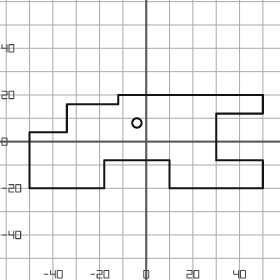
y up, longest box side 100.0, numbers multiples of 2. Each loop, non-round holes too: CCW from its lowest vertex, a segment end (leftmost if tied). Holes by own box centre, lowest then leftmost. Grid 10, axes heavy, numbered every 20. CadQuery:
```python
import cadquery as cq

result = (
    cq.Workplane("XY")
    .moveTo(-50.0, -20.0)
    .lineTo(-18.0, -20.0)
    .lineTo(-18.0, -8.0)
    .lineTo(10.0, -8.0)
    .lineTo(10.0, -20.0)
    .lineTo(50.0, -20.0)
    .lineTo(50.0, -8.0)
    .lineTo(30.0, -8.0)
    .lineTo(30.0, 12.0)
    .lineTo(50.0, 12.0)
    .lineTo(50.0, 20.0)
    .lineTo(-12.0, 20.0)
    .lineTo(-12.0, 16.0)
    .lineTo(-34.0, 16.0)
    .lineTo(-34.0, 4.0)
    .lineTo(-50.0, 4.0)
    .close()
    .moveTo(-4.0, 8.0)
    .circle(2.0)
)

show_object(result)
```